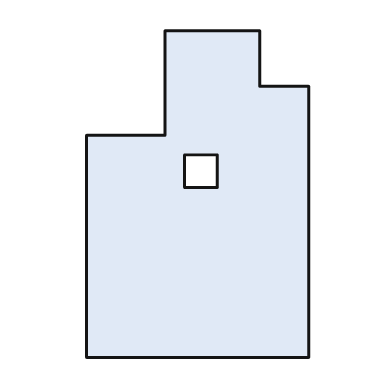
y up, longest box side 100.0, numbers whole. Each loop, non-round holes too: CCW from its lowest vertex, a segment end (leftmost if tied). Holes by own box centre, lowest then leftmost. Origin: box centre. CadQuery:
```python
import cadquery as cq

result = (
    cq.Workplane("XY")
    .moveTo(-34.0, -50.0)
    .lineTo(34.0, -50.0)
    .lineTo(34.0, 33.0)
    .lineTo(19.0, 33.0)
    .lineTo(19.0, 50.0)
    .lineTo(-10.0, 50.0)
    .lineTo(-10.0, 18.0)
    .lineTo(-34.0, 18.0)
    .close()
    .moveTo(-4.0, 2.0)
    .lineTo(6.0, 2.0)
    .lineTo(6.0, 12.0)
    .lineTo(-4.0, 12.0)
    .close()
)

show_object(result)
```